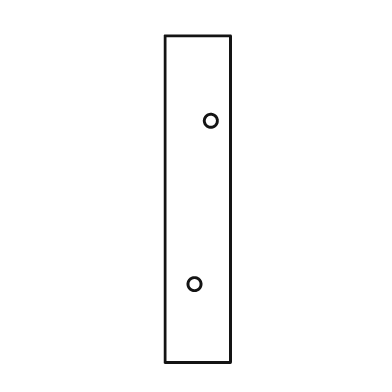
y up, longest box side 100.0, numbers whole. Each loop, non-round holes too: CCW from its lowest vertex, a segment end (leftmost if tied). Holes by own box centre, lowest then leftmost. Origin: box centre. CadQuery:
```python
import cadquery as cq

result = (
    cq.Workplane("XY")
    .moveTo(-10.0, -50.0)
    .lineTo(10.0, -50.0)
    .lineTo(10.0, 50.0)
    .lineTo(-10.0, 50.0)
    .close()
    .moveTo(-1.0, -26.0)
    .circle(2.0)
    .moveTo(4.0, 24.0)
    .circle(2.0)
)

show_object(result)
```